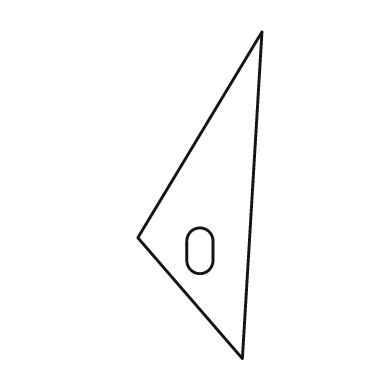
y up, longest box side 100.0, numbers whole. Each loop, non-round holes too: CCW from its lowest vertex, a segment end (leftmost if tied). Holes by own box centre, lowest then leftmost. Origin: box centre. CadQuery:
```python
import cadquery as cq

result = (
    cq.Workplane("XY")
    .moveTo(13.0, -50.0)
    .lineTo(19.0, 50.0)
    .lineTo(-19.0, -13.0)
    .close()
    .moveTo(-4.0, -20.0)
    .threePointArc((0.0, -24.0), (4.0, -20.0))
    .lineTo(4.0, -14.0)
    .threePointArc((0.0, -10.0), (-4.0, -14.0))
    .close()
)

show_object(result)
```